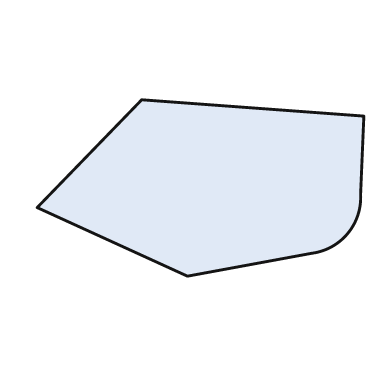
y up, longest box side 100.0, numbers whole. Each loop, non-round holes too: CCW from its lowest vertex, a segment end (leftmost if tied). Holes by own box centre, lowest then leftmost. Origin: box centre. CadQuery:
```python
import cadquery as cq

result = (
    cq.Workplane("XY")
    .moveTo(-4.0, -27.0)
    .lineTo(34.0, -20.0)
    .threePointArc((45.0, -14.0), (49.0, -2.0))
    .lineTo(50.0, 22.0)
    .lineTo(-18.0, 27.0)
    .lineTo(-50.0, -6.0)
    .close()
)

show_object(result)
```